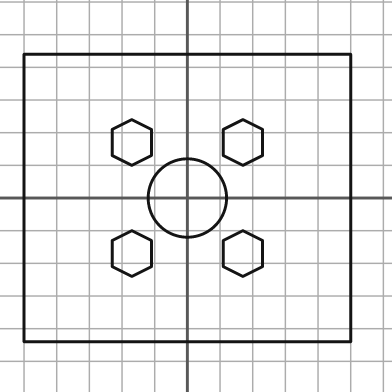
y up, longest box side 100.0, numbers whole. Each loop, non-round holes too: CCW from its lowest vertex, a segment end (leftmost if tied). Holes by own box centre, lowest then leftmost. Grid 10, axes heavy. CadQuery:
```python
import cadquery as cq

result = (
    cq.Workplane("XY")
    .moveTo(-50.0, -44.0)
    .lineTo(50.0, -44.0)
    .lineTo(50.0, 44.0)
    .lineTo(-50.0, 44.0)
    .close()
    .moveTo(-17.0, -24.0)
    .lineTo(-11.0, -21.0)
    .lineTo(-11.0, -13.0)
    .lineTo(-17.0, -10.0)
    .lineTo(-23.0, -13.0)
    .lineTo(-23.0, -21.0)
    .close()
    .moveTo(17.0, -24.0)
    .lineTo(23.0, -21.0)
    .lineTo(23.0, -13.0)
    .lineTo(17.0, -10.0)
    .lineTo(11.0, -13.0)
    .lineTo(11.0, -21.0)
    .close()
    .moveTo(0.0, 0.0)
    .circle(12.0)
    .moveTo(-17.0, 10.0)
    .lineTo(-11.0, 13.0)
    .lineTo(-11.0, 21.0)
    .lineTo(-17.0, 24.0)
    .lineTo(-23.0, 21.0)
    .lineTo(-23.0, 13.0)
    .close()
    .moveTo(17.0, 10.0)
    .lineTo(23.0, 13.0)
    .lineTo(23.0, 21.0)
    .lineTo(17.0, 24.0)
    .lineTo(11.0, 21.0)
    .lineTo(11.0, 13.0)
    .close()
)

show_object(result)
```